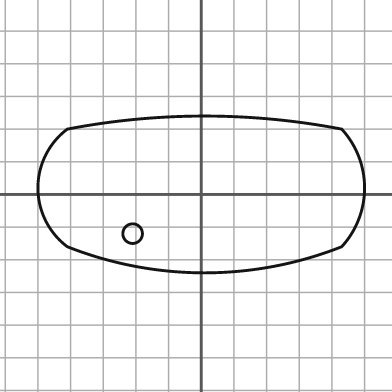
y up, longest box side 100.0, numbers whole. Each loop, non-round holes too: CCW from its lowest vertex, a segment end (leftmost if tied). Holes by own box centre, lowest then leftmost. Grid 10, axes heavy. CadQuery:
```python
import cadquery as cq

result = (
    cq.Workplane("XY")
    .moveTo(-41.0, -16.0)
    .threePointArc((1.0, -24.0), (43.0, -16.0))
    .threePointArc((50.0, 2.0), (43.0, 20.0))
    .threePointArc((1.0, 24.0), (-41.0, 20.0))
    .threePointArc((-50.0, 2.0), (-41.0, -16.0))
    .close()
    .moveTo(-21.0, -12.0)
    .circle(3.0)
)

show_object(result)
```